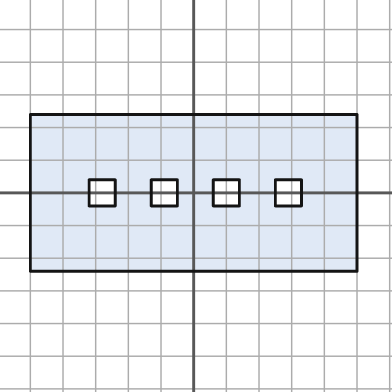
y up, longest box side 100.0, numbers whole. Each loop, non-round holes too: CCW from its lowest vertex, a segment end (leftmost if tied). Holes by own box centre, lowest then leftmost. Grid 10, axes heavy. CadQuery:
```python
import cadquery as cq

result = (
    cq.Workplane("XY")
    .moveTo(-50.0, -24.0)
    .lineTo(50.0, -24.0)
    .lineTo(50.0, 24.0)
    .lineTo(-50.0, 24.0)
    .close()
    .moveTo(-32.0, -4.0)
    .lineTo(-24.0, -4.0)
    .lineTo(-24.0, 4.0)
    .lineTo(-32.0, 4.0)
    .close()
    .moveTo(-13.0, -4.0)
    .lineTo(-5.0, -4.0)
    .lineTo(-5.0, 4.0)
    .lineTo(-13.0, 4.0)
    .close()
    .moveTo(6.0, -4.0)
    .lineTo(14.0, -4.0)
    .lineTo(14.0, 4.0)
    .lineTo(6.0, 4.0)
    .close()
    .moveTo(25.0, -4.0)
    .lineTo(33.0, -4.0)
    .lineTo(33.0, 4.0)
    .lineTo(25.0, 4.0)
    .close()
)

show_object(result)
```